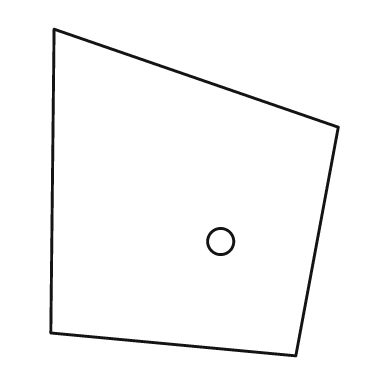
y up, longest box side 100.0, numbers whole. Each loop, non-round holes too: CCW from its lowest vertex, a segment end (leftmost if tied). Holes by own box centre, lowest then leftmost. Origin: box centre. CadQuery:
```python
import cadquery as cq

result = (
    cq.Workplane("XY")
    .moveTo(31.0, -50.0)
    .lineTo(44.0, 20.0)
    .lineTo(-43.0, 50.0)
    .lineTo(-44.0, -43.0)
    .close()
    .moveTo(8.0, -15.0)
    .circle(4.0)
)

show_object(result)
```